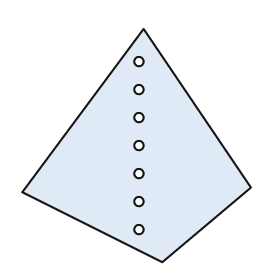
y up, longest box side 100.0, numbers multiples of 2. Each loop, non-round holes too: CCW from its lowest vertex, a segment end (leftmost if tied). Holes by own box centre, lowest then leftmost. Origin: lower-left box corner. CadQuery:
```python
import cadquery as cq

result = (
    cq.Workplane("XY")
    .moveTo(60.0, 0.0)
    .lineTo(98.0, 32.0)
    .lineTo(52.0, 100.0)
    .lineTo(0.0, 30.0)
    .close()
    .moveTo(50.0, 14.0)
    .circle(2.0)
    .moveTo(50.0, 26.0)
    .circle(2.0)
    .moveTo(50.0, 38.0)
    .circle(2.0)
    .moveTo(50.0, 50.0)
    .circle(2.0)
    .moveTo(50.0, 62.0)
    .circle(2.0)
    .moveTo(50.0, 74.0)
    .circle(2.0)
    .moveTo(50.0, 86.0)
    .circle(2.0)
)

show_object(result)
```